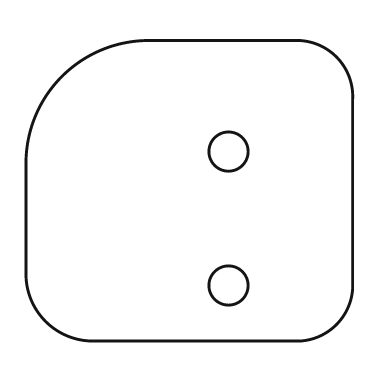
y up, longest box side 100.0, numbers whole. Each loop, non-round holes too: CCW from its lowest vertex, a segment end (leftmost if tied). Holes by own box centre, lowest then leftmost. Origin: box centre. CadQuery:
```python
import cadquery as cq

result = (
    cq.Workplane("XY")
    .moveTo(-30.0, -46.0)
    .lineTo(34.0, -46.0)
    .threePointArc((45.0, -41.0), (50.0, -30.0))
    .lineTo(50.0, 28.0)
    .threePointArc((45.0, 41.0), (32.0, 46.0))
    .lineTo(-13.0, 46.0)
    .threePointArc((-39.0, 35.0), (-50.0, 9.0))
    .lineTo(-50.0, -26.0)
    .threePointArc((-44.0, -40.0), (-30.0, -46.0))
    .close()
    .moveTo(12.0, -29.0)
    .circle(6.0)
    .moveTo(12.0, 12.0)
    .circle(6.0)
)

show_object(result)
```